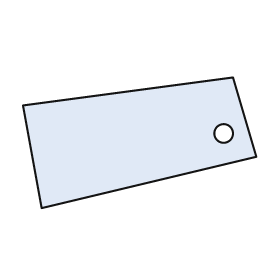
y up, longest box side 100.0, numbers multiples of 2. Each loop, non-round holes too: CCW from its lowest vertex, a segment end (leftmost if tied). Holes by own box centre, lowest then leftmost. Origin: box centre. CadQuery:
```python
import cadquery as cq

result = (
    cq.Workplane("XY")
    .moveTo(-42.0, -28.0)
    .lineTo(50.0, -6.0)
    .lineTo(40.0, 28.0)
    .lineTo(-50.0, 16.0)
    .close()
    .moveTo(36.0, 4.0)
    .circle(4.0)
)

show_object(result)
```